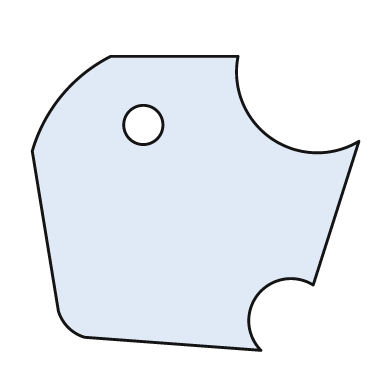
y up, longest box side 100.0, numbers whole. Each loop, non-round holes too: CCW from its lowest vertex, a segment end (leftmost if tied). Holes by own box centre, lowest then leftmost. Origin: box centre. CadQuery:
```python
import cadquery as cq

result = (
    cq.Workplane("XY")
    .moveTo(20.0, -45.0)
    .threePointArc((19.0, -28.0), (36.0, -25.0))
    .lineTo(50.0, 19.0)
    .threePointArc((23.0, 20.0), (13.0, 45.0))
    .lineTo(-26.0, 45.0)
    .threePointArc((-41.0, 33.0), (-50.0, 16.0))
    .lineTo(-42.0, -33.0)
    .threePointArc((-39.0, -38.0), (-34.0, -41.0))
    .close()
    .moveTo(-16.0, 24.0)
    .circle(6.0)
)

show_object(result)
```